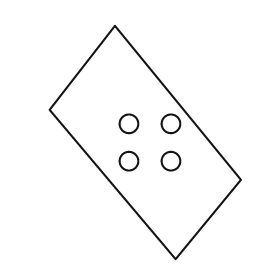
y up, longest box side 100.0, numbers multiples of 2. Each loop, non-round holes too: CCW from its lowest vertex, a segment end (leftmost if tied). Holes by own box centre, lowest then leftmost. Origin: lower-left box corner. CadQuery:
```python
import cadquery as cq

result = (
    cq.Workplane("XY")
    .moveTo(54.0, 0.0)
    .lineTo(82.0, 34.0)
    .lineTo(28.0, 100.0)
    .lineTo(0.0, 64.0)
    .close()
    .moveTo(34.0, 42.0)
    .circle(4.0)
    .moveTo(52.0, 42.0)
    .circle(4.0)
    .moveTo(34.0, 58.0)
    .circle(4.0)
    .moveTo(52.0, 58.0)
    .circle(4.0)
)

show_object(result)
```